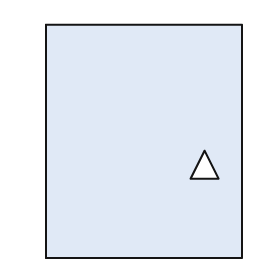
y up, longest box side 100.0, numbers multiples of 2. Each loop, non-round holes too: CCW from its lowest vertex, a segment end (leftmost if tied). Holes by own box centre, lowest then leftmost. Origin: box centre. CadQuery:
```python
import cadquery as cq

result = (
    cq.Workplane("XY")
    .moveTo(-42.0, -50.0)
    .lineTo(42.0, -50.0)
    .lineTo(42.0, 50.0)
    .lineTo(-42.0, 50.0)
    .close()
    .moveTo(20.0, -16.0)
    .lineTo(32.0, -16.0)
    .lineTo(26.0, -4.0)
    .close()
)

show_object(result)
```